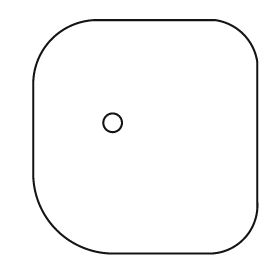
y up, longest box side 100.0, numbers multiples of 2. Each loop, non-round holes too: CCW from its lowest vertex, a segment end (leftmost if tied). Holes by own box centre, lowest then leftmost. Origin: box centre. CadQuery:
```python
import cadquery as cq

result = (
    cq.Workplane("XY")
    .moveTo(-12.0, -50.0)
    .lineTo(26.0, -50.0)
    .threePointArc((42.0, -44.0), (48.0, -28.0))
    .lineTo(48.0, 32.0)
    .threePointArc((42.0, 44.0), (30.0, 50.0))
    .lineTo(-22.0, 50.0)
    .threePointArc((-40.0, 42.0), (-48.0, 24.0))
    .lineTo(-48.0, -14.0)
    .threePointArc((-38.0, -40.0), (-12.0, -50.0))
    .close()
    .moveTo(-14.0, 6.0)
    .circle(4.0)
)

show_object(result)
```